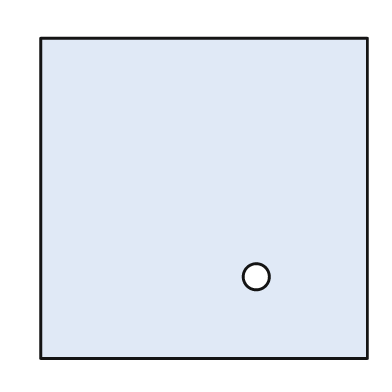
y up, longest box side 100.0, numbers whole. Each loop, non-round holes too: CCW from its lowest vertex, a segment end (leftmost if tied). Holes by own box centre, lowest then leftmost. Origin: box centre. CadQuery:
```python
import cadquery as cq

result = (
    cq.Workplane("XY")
    .moveTo(-50.0, -49.0)
    .lineTo(50.0, -49.0)
    .lineTo(50.0, 49.0)
    .lineTo(-50.0, 49.0)
    .close()
    .moveTo(16.0, -24.0)
    .circle(4.0)
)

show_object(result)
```